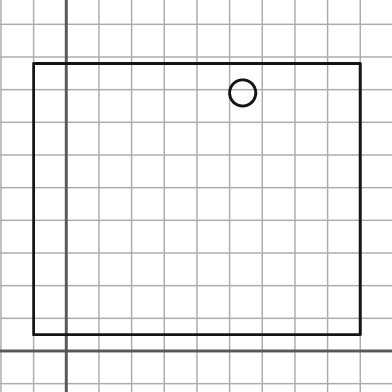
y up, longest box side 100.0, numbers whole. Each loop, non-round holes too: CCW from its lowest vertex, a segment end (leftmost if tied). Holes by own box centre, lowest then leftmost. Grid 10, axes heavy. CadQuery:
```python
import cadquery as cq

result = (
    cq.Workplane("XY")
    .moveTo(-10.0, 5.0)
    .lineTo(90.0, 5.0)
    .lineTo(90.0, 88.0)
    .lineTo(-10.0, 88.0)
    .close()
    .moveTo(54.0, 79.0)
    .circle(4.0)
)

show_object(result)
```